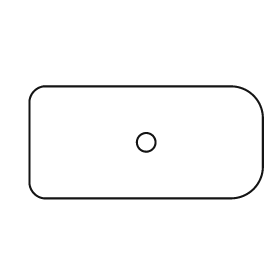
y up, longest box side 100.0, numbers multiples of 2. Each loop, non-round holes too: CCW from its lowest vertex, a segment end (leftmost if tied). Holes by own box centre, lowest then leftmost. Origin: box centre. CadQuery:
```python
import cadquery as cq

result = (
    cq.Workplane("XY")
    .moveTo(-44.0, -24.0)
    .lineTo(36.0, -24.0)
    .threePointArc((46.0, -20.0), (50.0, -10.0))
    .lineTo(50.0, 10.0)
    .threePointArc((46.0, 20.0), (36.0, 24.0))
    .lineTo(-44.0, 24.0)
    .threePointArc((-48.0, 22.0), (-50.0, 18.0))
    .lineTo(-50.0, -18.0)
    .threePointArc((-48.0, -22.0), (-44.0, -24.0))
    .close()
    .moveTo(0.0, 0.0)
    .circle(4.0)
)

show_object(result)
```